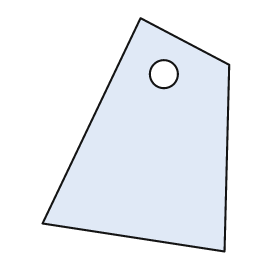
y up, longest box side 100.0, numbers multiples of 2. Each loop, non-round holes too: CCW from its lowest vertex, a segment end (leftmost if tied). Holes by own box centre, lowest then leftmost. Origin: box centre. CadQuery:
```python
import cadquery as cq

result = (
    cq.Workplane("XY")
    .moveTo(38.0, -50.0)
    .lineTo(40.0, 30.0)
    .lineTo(2.0, 50.0)
    .lineTo(-40.0, -38.0)
    .close()
    .moveTo(12.0, 26.0)
    .circle(6.0)
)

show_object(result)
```